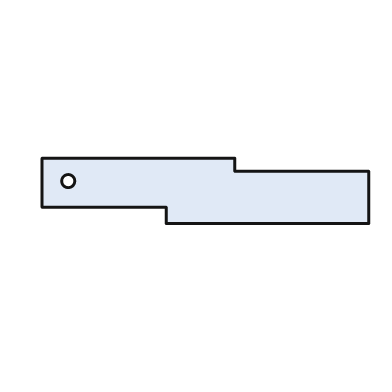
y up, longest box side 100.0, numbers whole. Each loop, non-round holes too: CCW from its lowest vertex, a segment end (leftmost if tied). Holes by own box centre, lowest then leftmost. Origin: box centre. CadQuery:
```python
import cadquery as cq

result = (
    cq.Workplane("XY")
    .moveTo(-12.0, -10.0)
    .lineTo(50.0, -10.0)
    .lineTo(50.0, 6.0)
    .lineTo(9.0, 6.0)
    .lineTo(9.0, 10.0)
    .lineTo(-50.0, 10.0)
    .lineTo(-50.0, -5.0)
    .lineTo(-12.0, -5.0)
    .close()
    .moveTo(-42.0, 3.0)
    .circle(2.0)
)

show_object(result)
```